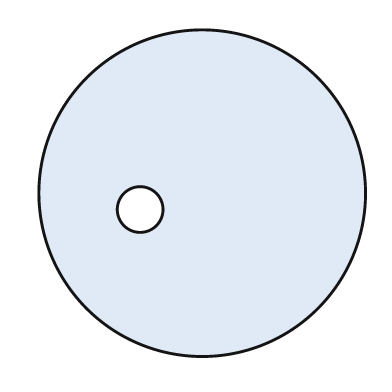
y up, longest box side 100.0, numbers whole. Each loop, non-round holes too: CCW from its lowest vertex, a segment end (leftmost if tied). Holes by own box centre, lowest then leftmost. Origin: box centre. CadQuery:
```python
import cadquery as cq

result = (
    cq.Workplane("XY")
    .moveTo(0.0, 0.0)
    .circle(50.0)
    .moveTo(-19.0, -5.0)
    .circle(7.0)
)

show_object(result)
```